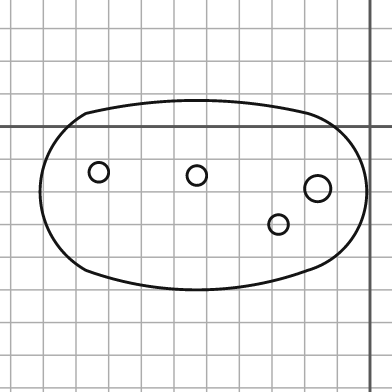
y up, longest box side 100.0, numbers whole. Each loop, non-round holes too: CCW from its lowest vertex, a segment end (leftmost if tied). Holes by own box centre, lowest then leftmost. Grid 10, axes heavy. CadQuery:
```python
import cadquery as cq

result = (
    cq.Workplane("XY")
    .moveTo(-87.0, -44.0)
    .threePointArc((-53.0, -50.0), (-19.0, -44.0))
    .threePointArc((-1.0, -20.0), (-19.0, 4.0))
    .threePointArc((-53.0, 8.0), (-87.0, 4.0))
    .threePointArc((-101.0, -20.0), (-87.0, -44.0))
    .close()
    .moveTo(-28.0, -30.0)
    .circle(3.0)
    .moveTo(-16.0, -19.0)
    .circle(4.0)
    .moveTo(-53.0, -15.0)
    .circle(3.0)
    .moveTo(-83.0, -14.0)
    .circle(3.0)
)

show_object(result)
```